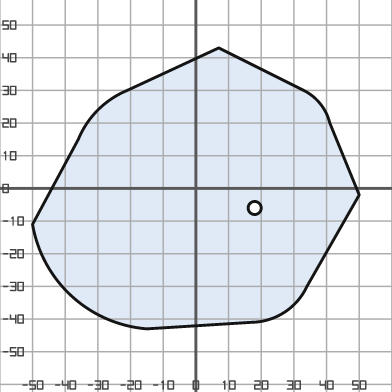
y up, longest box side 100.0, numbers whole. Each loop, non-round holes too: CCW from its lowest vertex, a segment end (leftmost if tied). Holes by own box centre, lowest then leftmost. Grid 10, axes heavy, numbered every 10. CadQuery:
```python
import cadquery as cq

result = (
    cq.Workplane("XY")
    .moveTo(-15.0, -43.0)
    .lineTo(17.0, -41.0)
    .threePointArc((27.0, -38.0), (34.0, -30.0))
    .lineTo(50.0, -2.0)
    .lineTo(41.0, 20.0)
    .threePointArc((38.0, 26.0), (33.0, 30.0))
    .lineTo(7.0, 43.0)
    .lineTo(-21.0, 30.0)
    .threePointArc((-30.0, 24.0), (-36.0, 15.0))
    .lineTo(-50.0, -11.0)
    .threePointArc((-38.0, -33.0), (-15.0, -43.0))
    .close()
    .moveTo(18.0, -6.0)
    .circle(2.0)
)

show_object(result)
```